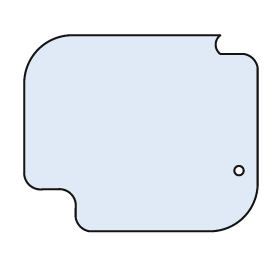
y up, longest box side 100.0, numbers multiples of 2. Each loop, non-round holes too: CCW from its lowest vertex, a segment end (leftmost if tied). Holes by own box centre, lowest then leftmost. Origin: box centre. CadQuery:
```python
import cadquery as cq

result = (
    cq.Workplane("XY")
    .moveTo(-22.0, -42.0)
    .lineTo(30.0, -42.0)
    .threePointArc((44.0, -36.0), (50.0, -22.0))
    .lineTo(50.0, 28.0)
    .threePointArc((48.0, 32.0), (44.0, 34.0))
    .lineTo(34.0, 34.0)
    .threePointArc((32.0, 38.0), (34.0, 42.0))
    .lineTo(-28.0, 42.0)
    .threePointArc((-44.0, 36.0), (-50.0, 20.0))
    .lineTo(-50.0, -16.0)
    .threePointArc((-48.0, -22.0), (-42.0, -24.0))
    .lineTo(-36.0, -24.0)
    .threePointArc((-30.0, -26.0), (-28.0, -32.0))
    .lineTo(-28.0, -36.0)
    .threePointArc((-26.0, -40.0), (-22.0, -42.0))
    .close()
    .moveTo(42.0, -16.0)
    .circle(2.0)
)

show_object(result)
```